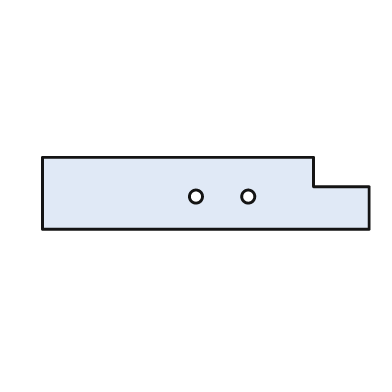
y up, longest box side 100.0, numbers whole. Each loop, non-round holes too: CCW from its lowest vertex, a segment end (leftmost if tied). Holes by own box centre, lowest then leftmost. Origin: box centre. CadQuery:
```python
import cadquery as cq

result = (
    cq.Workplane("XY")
    .moveTo(-50.0, -11.0)
    .lineTo(50.0, -11.0)
    .lineTo(50.0, 2.0)
    .lineTo(33.0, 2.0)
    .lineTo(33.0, 11.0)
    .lineTo(-50.0, 11.0)
    .close()
    .moveTo(-3.0, -1.0)
    .circle(2.0)
    .moveTo(13.0, -1.0)
    .circle(2.0)
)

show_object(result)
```